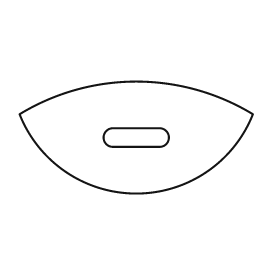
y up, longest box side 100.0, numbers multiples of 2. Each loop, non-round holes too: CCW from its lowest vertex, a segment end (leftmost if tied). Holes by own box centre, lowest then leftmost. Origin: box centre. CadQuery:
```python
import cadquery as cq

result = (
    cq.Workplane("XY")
    .moveTo(-50.0, 10.0)
    .threePointArc((0.0, -24.0), (50.0, 10.0))
    .threePointArc((0.0, 24.0), (-50.0, 10.0))
    .close()
    .moveTo(-10.0, -4.0)
    .lineTo(10.0, -4.0)
    .threePointArc((14.0, 0.0), (10.0, 4.0))
    .lineTo(-10.0, 4.0)
    .threePointArc((-14.0, 0.0), (-10.0, -4.0))
    .close()
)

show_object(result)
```